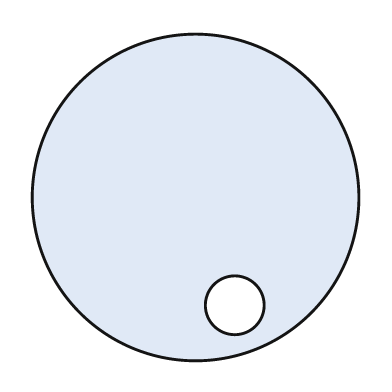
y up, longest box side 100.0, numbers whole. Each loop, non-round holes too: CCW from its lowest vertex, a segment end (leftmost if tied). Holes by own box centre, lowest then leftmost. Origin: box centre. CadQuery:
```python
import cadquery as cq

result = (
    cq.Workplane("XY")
    .moveTo(0.0, 0.0)
    .circle(50.0)
    .moveTo(12.0, -33.0)
    .circle(9.0)
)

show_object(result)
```